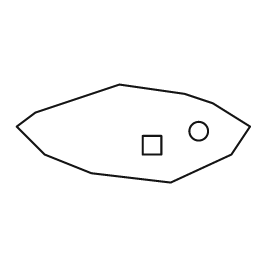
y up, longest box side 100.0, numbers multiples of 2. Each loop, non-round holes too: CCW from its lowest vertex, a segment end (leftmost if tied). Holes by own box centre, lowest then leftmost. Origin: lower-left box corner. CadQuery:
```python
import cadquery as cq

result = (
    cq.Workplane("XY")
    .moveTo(66.0, 0.0)
    .lineTo(92.0, 12.0)
    .lineTo(100.0, 24.0)
    .lineTo(84.0, 34.0)
    .lineTo(72.0, 38.0)
    .lineTo(44.0, 42.0)
    .lineTo(8.0, 30.0)
    .lineTo(0.0, 24.0)
    .lineTo(12.0, 12.0)
    .lineTo(32.0, 4.0)
    .close()
    .moveTo(54.0, 12.0)
    .lineTo(62.0, 12.0)
    .lineTo(62.0, 20.0)
    .lineTo(54.0, 20.0)
    .close()
    .moveTo(78.0, 22.0)
    .circle(4.0)
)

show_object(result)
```